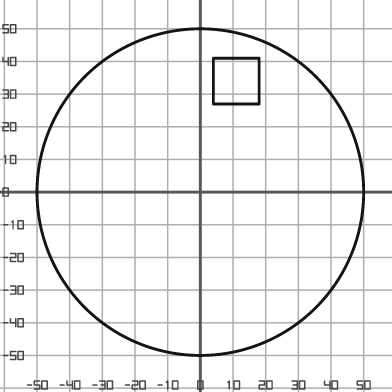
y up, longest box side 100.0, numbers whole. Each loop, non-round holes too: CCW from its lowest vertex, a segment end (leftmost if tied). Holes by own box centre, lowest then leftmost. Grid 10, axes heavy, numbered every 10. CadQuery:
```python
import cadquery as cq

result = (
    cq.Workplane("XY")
    .moveTo(0.0, 0.0)
    .circle(50.0)
    .moveTo(4.0, 27.0)
    .lineTo(18.0, 27.0)
    .lineTo(18.0, 41.0)
    .lineTo(4.0, 41.0)
    .close()
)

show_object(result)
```